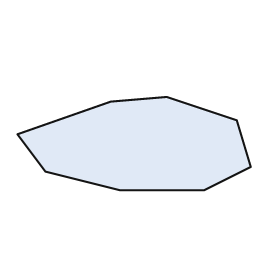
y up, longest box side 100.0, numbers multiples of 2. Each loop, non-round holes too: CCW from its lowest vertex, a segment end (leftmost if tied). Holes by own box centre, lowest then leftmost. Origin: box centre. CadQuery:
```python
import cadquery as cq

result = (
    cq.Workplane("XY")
    .moveTo(-6.0, -20.0)
    .lineTo(30.0, -20.0)
    .lineTo(50.0, -10.0)
    .lineTo(44.0, 10.0)
    .lineTo(14.0, 20.0)
    .lineTo(-10.0, 18.0)
    .lineTo(-50.0, 4.0)
    .lineTo(-38.0, -12.0)
    .close()
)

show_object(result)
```